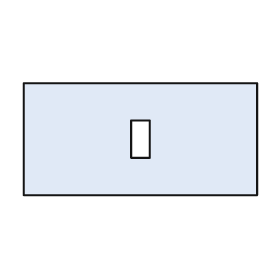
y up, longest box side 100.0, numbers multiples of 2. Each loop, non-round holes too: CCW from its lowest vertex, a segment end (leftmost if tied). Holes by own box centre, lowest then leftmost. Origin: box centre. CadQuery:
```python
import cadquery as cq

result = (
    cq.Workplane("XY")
    .moveTo(-50.0, -24.0)
    .lineTo(50.0, -24.0)
    .lineTo(50.0, 24.0)
    .lineTo(-50.0, 24.0)
    .close()
    .moveTo(-4.0, -8.0)
    .lineTo(4.0, -8.0)
    .lineTo(4.0, 8.0)
    .lineTo(-4.0, 8.0)
    .close()
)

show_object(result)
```